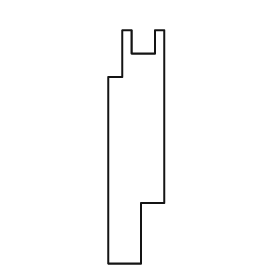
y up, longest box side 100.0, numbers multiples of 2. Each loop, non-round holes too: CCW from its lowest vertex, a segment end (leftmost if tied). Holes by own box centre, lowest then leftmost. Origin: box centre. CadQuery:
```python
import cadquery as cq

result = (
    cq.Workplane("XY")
    .moveTo(-12.0, -50.0)
    .lineTo(2.0, -50.0)
    .lineTo(2.0, -24.0)
    .lineTo(12.0, -24.0)
    .lineTo(12.0, 50.0)
    .lineTo(8.0, 50.0)
    .lineTo(8.0, 40.0)
    .lineTo(-2.0, 40.0)
    .lineTo(-2.0, 50.0)
    .lineTo(-6.0, 50.0)
    .lineTo(-6.0, 30.0)
    .lineTo(-12.0, 30.0)
    .close()
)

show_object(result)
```